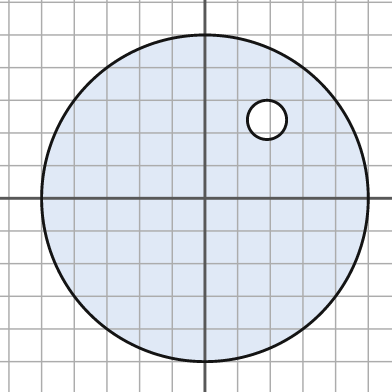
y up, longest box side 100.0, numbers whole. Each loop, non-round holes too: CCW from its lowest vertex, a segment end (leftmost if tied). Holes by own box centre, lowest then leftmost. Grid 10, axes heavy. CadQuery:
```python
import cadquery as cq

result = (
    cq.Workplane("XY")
    .moveTo(0.0, 0.0)
    .circle(50.0)
    .moveTo(19.0, 24.0)
    .circle(6.0)
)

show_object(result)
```